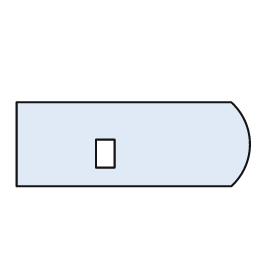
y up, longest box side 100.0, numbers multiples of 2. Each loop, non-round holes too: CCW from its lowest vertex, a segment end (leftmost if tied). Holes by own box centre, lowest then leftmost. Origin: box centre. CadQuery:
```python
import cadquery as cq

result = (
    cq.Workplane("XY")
    .moveTo(-50.0, -18.0)
    .lineTo(42.0, -18.0)
    .threePointArc((50.0, 0.0), (42.0, 18.0))
    .lineTo(-50.0, 18.0)
    .close()
    .moveTo(-16.0, -10.0)
    .lineTo(-8.0, -10.0)
    .lineTo(-8.0, 2.0)
    .lineTo(-16.0, 2.0)
    .close()
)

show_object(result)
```